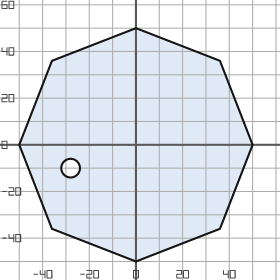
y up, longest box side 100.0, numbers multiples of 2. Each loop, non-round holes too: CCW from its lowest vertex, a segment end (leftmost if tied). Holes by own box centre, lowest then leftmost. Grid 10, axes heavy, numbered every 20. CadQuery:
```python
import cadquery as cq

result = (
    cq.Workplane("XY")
    .moveTo(0.0, -50.0)
    .lineTo(36.0, -36.0)
    .lineTo(50.0, 0.0)
    .lineTo(36.0, 36.0)
    .lineTo(0.0, 50.0)
    .lineTo(-36.0, 36.0)
    .lineTo(-50.0, 0.0)
    .lineTo(-36.0, -36.0)
    .close()
    .moveTo(-28.0, -10.0)
    .circle(4.0)
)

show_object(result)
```